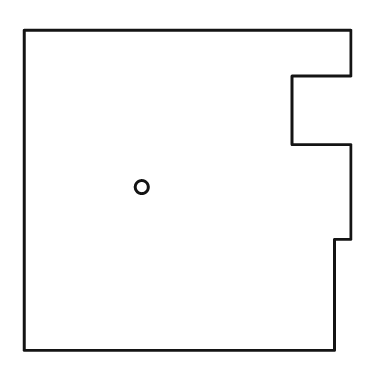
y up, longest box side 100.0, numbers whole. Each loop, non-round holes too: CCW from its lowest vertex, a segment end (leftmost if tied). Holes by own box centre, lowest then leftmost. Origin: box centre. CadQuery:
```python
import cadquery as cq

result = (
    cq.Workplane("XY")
    .moveTo(-50.0, -49.0)
    .lineTo(45.0, -49.0)
    .lineTo(45.0, -15.0)
    .lineTo(50.0, -15.0)
    .lineTo(50.0, 14.0)
    .lineTo(32.0, 14.0)
    .lineTo(32.0, 35.0)
    .lineTo(50.0, 35.0)
    .lineTo(50.0, 49.0)
    .lineTo(-50.0, 49.0)
    .close()
    .moveTo(-14.0, 1.0)
    .circle(2.0)
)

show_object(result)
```